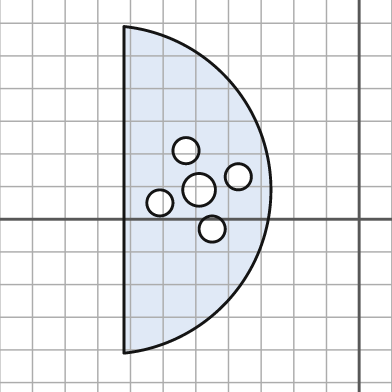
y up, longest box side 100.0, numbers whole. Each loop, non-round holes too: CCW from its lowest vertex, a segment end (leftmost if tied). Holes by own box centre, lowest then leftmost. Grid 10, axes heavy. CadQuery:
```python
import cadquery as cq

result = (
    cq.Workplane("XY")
    .moveTo(-72.0, -41.0)
    .threePointArc((-27.0, 9.0), (-72.0, 59.0))
    .close()
    .moveTo(-45.0, -3.0)
    .circle(4.0)
    .moveTo(-61.0, 5.0)
    .circle(4.0)
    .moveTo(-49.0, 9.0)
    .circle(5.0)
    .moveTo(-37.0, 13.0)
    .circle(4.0)
    .moveTo(-53.0, 21.0)
    .circle(4.0)
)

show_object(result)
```